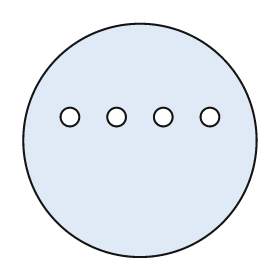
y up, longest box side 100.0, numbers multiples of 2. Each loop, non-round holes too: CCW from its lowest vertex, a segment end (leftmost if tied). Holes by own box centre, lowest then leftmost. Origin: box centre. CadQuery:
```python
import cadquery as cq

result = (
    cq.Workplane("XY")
    .moveTo(0.0, 0.0)
    .circle(50.0)
    .moveTo(-30.0, 10.0)
    .circle(4.0)
    .moveTo(-10.0, 10.0)
    .circle(4.0)
    .moveTo(10.0, 10.0)
    .circle(4.0)
    .moveTo(30.0, 10.0)
    .circle(4.0)
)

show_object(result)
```